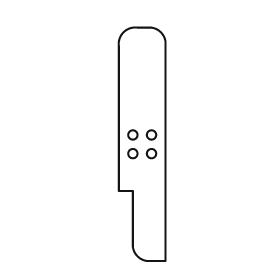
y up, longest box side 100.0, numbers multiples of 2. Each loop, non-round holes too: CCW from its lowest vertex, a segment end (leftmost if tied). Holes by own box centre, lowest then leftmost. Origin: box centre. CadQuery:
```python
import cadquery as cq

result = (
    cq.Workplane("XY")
    .moveTo(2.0, -50.0)
    .lineTo(10.0, -50.0)
    .lineTo(10.0, 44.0)
    .threePointArc((8.0, 48.0), (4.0, 50.0))
    .lineTo(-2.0, 50.0)
    .threePointArc((-8.0, 48.0), (-10.0, 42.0))
    .lineTo(-10.0, -20.0)
    .lineTo(-4.0, -20.0)
    .lineTo(-4.0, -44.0)
    .threePointArc((-2.0, -48.0), (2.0, -50.0))
    .close()
    .moveTo(-4.0, -4.0)
    .circle(2.0)
    .moveTo(4.0, -4.0)
    .circle(2.0)
    .moveTo(-4.0, 4.0)
    .circle(2.0)
    .moveTo(4.0, 4.0)
    .circle(2.0)
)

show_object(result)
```